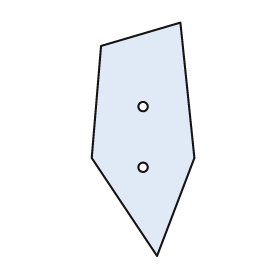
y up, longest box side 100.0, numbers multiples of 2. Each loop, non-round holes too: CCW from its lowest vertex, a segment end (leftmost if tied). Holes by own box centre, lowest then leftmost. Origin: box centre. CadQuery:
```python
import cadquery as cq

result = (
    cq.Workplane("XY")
    .moveTo(6.0, -50.0)
    .lineTo(22.0, -8.0)
    .lineTo(16.0, 50.0)
    .lineTo(-18.0, 40.0)
    .lineTo(-22.0, -8.0)
    .close()
    .moveTo(0.0, -12.0)
    .circle(2.0)
    .moveTo(0.0, 14.0)
    .circle(2.0)
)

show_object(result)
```